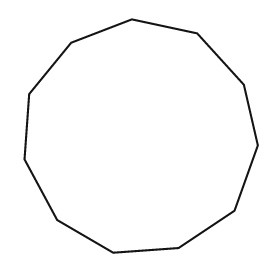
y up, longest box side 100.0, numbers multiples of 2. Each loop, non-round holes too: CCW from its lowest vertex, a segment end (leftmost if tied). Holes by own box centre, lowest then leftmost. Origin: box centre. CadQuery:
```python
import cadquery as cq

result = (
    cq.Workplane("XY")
    .moveTo(-12.0, -50.0)
    .lineTo(16.0, -48.0)
    .lineTo(40.0, -32.0)
    .lineTo(50.0, -4.0)
    .lineTo(44.0, 22.0)
    .lineTo(24.0, 44.0)
    .lineTo(-4.0, 50.0)
    .lineTo(-30.0, 40.0)
    .lineTo(-48.0, 18.0)
    .lineTo(-50.0, -10.0)
    .lineTo(-36.0, -36.0)
    .close()
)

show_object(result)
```